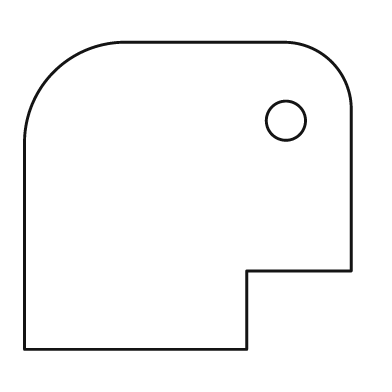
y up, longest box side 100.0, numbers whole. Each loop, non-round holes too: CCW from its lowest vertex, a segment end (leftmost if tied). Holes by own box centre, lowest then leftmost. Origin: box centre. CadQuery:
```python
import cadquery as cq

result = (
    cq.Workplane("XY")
    .moveTo(-50.0, -47.0)
    .lineTo(18.0, -47.0)
    .lineTo(18.0, -23.0)
    .lineTo(50.0, -23.0)
    .lineTo(50.0, 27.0)
    .threePointArc((44.0, 41.0), (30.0, 47.0))
    .lineTo(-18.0, 47.0)
    .threePointArc((-41.0, 38.0), (-50.0, 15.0))
    .close()
    .moveTo(30.0, 23.0)
    .circle(6.0)
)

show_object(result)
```